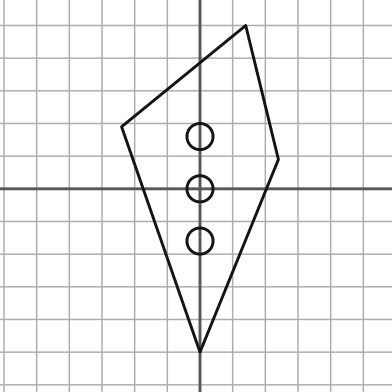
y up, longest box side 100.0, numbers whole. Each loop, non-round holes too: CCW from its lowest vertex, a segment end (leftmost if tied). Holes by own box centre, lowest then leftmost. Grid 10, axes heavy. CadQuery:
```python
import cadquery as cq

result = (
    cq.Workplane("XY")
    .moveTo(0.0, -50.0)
    .lineTo(24.0, 9.0)
    .lineTo(14.0, 50.0)
    .lineTo(-24.0, 19.0)
    .close()
    .moveTo(0.0, -16.0)
    .circle(4.0)
    .moveTo(0.0, 0.0)
    .circle(4.0)
    .moveTo(0.0, 16.0)
    .circle(4.0)
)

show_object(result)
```